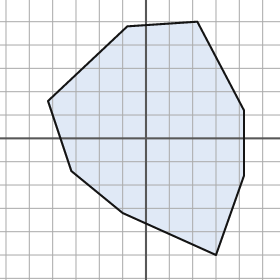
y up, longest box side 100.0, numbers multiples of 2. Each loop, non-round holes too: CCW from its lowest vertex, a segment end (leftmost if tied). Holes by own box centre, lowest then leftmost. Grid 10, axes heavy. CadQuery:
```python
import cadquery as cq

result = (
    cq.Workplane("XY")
    .moveTo(30.0, -50.0)
    .lineTo(42.0, -16.0)
    .lineTo(42.0, 12.0)
    .lineTo(22.0, 50.0)
    .lineTo(-8.0, 48.0)
    .lineTo(-42.0, 16.0)
    .lineTo(-32.0, -14.0)
    .lineTo(-10.0, -32.0)
    .close()
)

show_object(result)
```